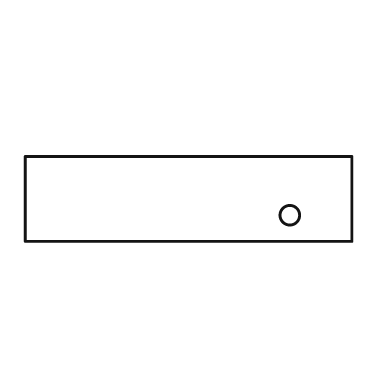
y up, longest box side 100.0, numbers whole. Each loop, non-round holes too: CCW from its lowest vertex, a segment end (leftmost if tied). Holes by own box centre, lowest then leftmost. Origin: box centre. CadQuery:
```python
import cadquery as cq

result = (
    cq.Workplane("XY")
    .moveTo(-50.0, -13.0)
    .lineTo(50.0, -13.0)
    .lineTo(50.0, 13.0)
    .lineTo(-50.0, 13.0)
    .close()
    .moveTo(31.0, -5.0)
    .circle(3.0)
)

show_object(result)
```